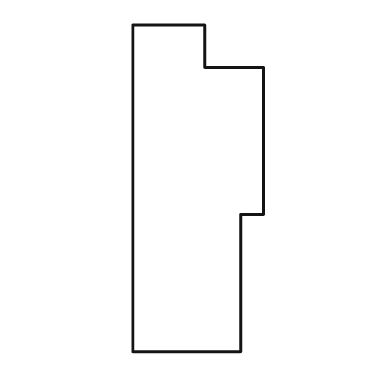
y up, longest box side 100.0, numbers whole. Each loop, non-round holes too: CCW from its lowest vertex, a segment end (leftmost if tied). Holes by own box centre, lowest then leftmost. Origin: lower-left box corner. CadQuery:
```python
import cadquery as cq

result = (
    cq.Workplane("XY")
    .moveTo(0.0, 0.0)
    .lineTo(33.0, 0.0)
    .lineTo(33.0, 42.0)
    .lineTo(40.0, 42.0)
    .lineTo(40.0, 87.0)
    .lineTo(22.0, 87.0)
    .lineTo(22.0, 100.0)
    .lineTo(0.0, 100.0)
    .close()
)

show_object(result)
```